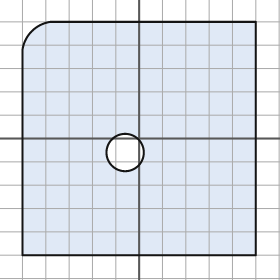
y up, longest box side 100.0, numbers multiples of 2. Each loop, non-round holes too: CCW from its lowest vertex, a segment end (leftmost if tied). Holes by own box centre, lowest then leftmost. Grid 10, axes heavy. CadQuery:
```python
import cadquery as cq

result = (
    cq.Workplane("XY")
    .moveTo(-50.0, -50.0)
    .lineTo(50.0, -50.0)
    .lineTo(50.0, 50.0)
    .lineTo(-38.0, 50.0)
    .threePointArc((-46.0, 46.0), (-50.0, 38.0))
    .close()
    .moveTo(-6.0, -6.0)
    .circle(8.0)
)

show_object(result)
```